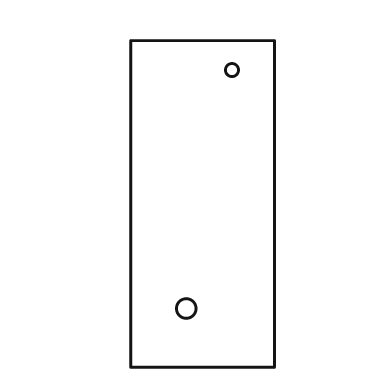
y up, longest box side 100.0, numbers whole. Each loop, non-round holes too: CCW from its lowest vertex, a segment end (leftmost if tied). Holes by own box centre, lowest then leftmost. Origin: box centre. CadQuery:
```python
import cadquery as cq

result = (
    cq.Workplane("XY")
    .moveTo(-22.0, -50.0)
    .lineTo(22.0, -50.0)
    .lineTo(22.0, 50.0)
    .lineTo(-22.0, 50.0)
    .close()
    .moveTo(-5.0, -32.0)
    .circle(3.0)
    .moveTo(9.0, 41.0)
    .circle(2.0)
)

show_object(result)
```